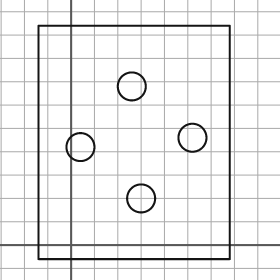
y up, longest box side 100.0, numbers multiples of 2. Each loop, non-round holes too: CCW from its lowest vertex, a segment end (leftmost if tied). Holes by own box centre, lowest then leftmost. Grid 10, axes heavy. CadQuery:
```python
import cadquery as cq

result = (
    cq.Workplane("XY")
    .moveTo(-14.0, -6.0)
    .lineTo(68.0, -6.0)
    .lineTo(68.0, 94.0)
    .lineTo(-14.0, 94.0)
    .close()
    .moveTo(30.0, 20.0)
    .circle(6.0)
    .moveTo(4.0, 42.0)
    .circle(6.0)
    .moveTo(52.0, 46.0)
    .circle(6.0)
    .moveTo(26.0, 68.0)
    .circle(6.0)
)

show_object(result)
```